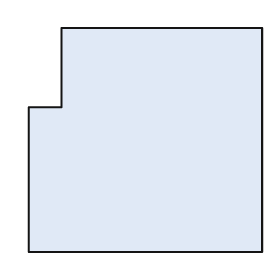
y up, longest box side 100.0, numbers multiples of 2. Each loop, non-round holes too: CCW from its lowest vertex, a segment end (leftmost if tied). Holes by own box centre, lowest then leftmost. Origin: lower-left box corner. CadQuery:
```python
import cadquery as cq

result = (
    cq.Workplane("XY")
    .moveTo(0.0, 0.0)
    .lineTo(100.0, 0.0)
    .lineTo(100.0, 96.0)
    .lineTo(14.0, 96.0)
    .lineTo(14.0, 62.0)
    .lineTo(0.0, 62.0)
    .close()
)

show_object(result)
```